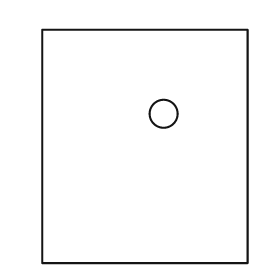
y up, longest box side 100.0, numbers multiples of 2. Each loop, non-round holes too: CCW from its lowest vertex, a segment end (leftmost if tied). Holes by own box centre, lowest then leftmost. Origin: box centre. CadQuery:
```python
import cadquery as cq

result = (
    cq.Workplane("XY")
    .moveTo(-44.0, -50.0)
    .lineTo(44.0, -50.0)
    .lineTo(44.0, 50.0)
    .lineTo(-44.0, 50.0)
    .close()
    .moveTo(8.0, 14.0)
    .circle(6.0)
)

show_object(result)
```